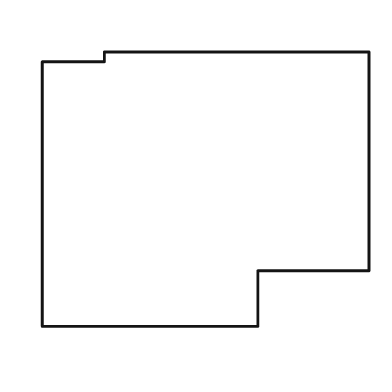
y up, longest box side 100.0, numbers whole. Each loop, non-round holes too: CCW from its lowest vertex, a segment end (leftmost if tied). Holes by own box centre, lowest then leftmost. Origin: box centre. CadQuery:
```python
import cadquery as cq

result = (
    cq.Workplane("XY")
    .moveTo(-50.0, -42.0)
    .lineTo(16.0, -42.0)
    .lineTo(16.0, -25.0)
    .lineTo(50.0, -25.0)
    .lineTo(50.0, 42.0)
    .lineTo(-31.0, 42.0)
    .lineTo(-31.0, 39.0)
    .lineTo(-50.0, 39.0)
    .close()
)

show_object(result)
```